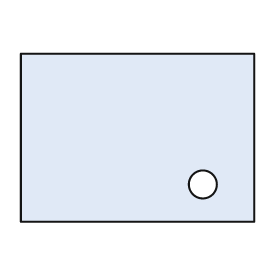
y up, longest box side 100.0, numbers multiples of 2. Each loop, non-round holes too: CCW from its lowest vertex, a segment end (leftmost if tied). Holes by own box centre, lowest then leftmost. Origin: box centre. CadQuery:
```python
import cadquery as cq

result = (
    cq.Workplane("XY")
    .moveTo(-50.0, -36.0)
    .lineTo(50.0, -36.0)
    .lineTo(50.0, 36.0)
    .lineTo(-50.0, 36.0)
    .close()
    .moveTo(28.0, -20.0)
    .circle(6.0)
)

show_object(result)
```